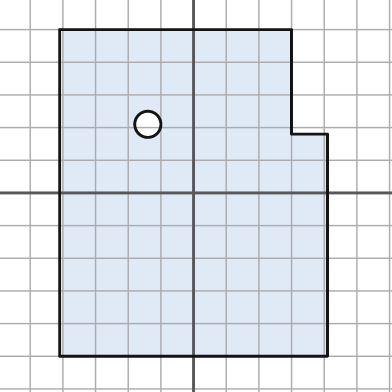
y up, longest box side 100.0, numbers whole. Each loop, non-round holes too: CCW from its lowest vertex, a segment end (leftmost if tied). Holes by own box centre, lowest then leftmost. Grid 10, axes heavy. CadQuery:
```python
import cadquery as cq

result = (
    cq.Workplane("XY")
    .moveTo(-41.0, -50.0)
    .lineTo(41.0, -50.0)
    .lineTo(41.0, 18.0)
    .lineTo(30.0, 18.0)
    .lineTo(30.0, 50.0)
    .lineTo(-41.0, 50.0)
    .close()
    .moveTo(-14.0, 21.0)
    .circle(4.0)
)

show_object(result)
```